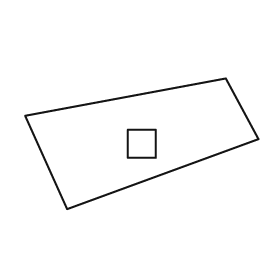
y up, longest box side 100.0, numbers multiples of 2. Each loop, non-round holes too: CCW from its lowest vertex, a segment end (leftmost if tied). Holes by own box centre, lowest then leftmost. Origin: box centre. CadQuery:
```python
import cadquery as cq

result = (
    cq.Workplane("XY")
    .moveTo(-32.0, -28.0)
    .lineTo(50.0, 2.0)
    .lineTo(36.0, 28.0)
    .lineTo(-50.0, 12.0)
    .close()
    .moveTo(-6.0, -6.0)
    .lineTo(6.0, -6.0)
    .lineTo(6.0, 6.0)
    .lineTo(-6.0, 6.0)
    .close()
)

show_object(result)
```